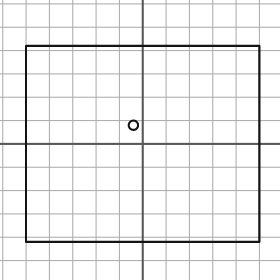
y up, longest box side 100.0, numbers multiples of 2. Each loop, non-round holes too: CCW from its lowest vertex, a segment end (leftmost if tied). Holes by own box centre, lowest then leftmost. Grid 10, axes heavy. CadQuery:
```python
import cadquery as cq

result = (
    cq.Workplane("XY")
    .moveTo(-50.0, -42.0)
    .lineTo(50.0, -42.0)
    .lineTo(50.0, 42.0)
    .lineTo(-50.0, 42.0)
    .close()
    .moveTo(-4.0, 8.0)
    .circle(2.0)
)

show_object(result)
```